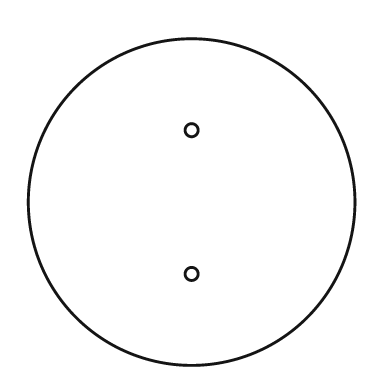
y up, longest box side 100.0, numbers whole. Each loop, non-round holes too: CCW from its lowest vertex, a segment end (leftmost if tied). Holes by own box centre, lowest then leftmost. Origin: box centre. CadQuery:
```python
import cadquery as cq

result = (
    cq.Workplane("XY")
    .moveTo(0.0, 0.0)
    .circle(50.0)
    .moveTo(0.0, -22.0)
    .circle(2.0)
    .moveTo(0.0, 22.0)
    .circle(2.0)
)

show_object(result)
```